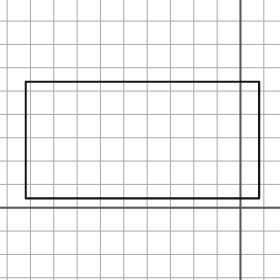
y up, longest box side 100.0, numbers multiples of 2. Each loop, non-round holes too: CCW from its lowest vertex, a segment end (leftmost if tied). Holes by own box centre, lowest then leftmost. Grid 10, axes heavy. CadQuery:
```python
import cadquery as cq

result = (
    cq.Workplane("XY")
    .moveTo(-92.0, 4.0)
    .lineTo(8.0, 4.0)
    .lineTo(8.0, 54.0)
    .lineTo(-92.0, 54.0)
    .close()
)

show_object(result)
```